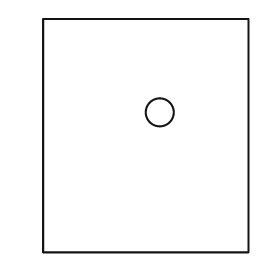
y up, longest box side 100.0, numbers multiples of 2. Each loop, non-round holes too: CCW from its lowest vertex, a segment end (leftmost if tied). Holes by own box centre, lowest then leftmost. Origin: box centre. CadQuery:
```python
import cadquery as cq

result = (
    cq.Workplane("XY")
    .moveTo(-44.0, -50.0)
    .lineTo(44.0, -50.0)
    .lineTo(44.0, 50.0)
    .lineTo(-44.0, 50.0)
    .close()
    .moveTo(6.0, 10.0)
    .circle(6.0)
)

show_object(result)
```